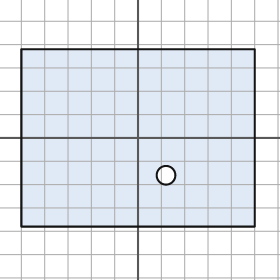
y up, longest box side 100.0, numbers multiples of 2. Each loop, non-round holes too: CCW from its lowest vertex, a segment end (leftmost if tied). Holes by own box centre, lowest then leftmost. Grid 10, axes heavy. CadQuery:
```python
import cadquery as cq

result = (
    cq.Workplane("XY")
    .moveTo(-50.0, -38.0)
    .lineTo(50.0, -38.0)
    .lineTo(50.0, 38.0)
    .lineTo(-50.0, 38.0)
    .close()
    .moveTo(12.0, -16.0)
    .circle(4.0)
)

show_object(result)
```